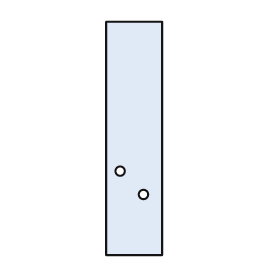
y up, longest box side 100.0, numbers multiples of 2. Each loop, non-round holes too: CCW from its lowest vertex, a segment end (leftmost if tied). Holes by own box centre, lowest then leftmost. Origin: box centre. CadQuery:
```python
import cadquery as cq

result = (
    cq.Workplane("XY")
    .moveTo(-12.0, -50.0)
    .lineTo(12.0, -50.0)
    .lineTo(12.0, 50.0)
    .lineTo(-12.0, 50.0)
    .close()
    .moveTo(4.0, -24.0)
    .circle(2.0)
    .moveTo(-6.0, -14.0)
    .circle(2.0)
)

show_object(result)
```